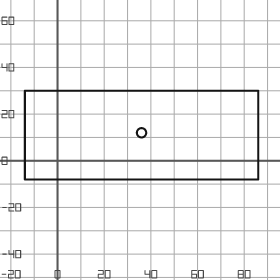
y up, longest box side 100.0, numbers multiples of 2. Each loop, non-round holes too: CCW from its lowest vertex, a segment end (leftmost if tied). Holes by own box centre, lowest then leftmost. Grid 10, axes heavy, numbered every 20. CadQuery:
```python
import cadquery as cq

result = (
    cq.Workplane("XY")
    .moveTo(-14.0, -8.0)
    .lineTo(86.0, -8.0)
    .lineTo(86.0, 30.0)
    .lineTo(-14.0, 30.0)
    .close()
    .moveTo(36.0, 12.0)
    .circle(2.0)
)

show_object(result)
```